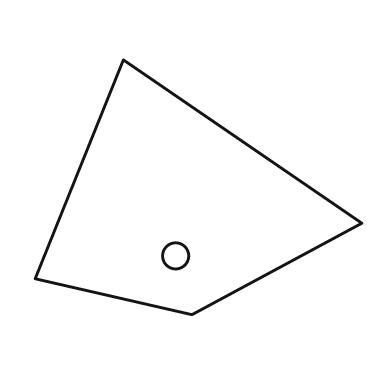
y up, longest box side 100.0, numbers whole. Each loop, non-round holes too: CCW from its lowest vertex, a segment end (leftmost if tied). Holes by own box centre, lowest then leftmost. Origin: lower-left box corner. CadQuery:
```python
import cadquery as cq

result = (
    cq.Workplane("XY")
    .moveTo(48.0, 0.0)
    .lineTo(100.0, 28.0)
    .lineTo(27.0, 78.0)
    .lineTo(0.0, 11.0)
    .close()
    .moveTo(43.0, 18.0)
    .circle(4.0)
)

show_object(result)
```